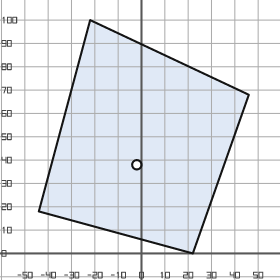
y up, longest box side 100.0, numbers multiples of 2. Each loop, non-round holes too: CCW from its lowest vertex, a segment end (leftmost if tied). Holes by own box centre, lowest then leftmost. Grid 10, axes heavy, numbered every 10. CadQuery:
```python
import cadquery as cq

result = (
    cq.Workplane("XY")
    .moveTo(22.0, 0.0)
    .lineTo(46.0, 68.0)
    .lineTo(-22.0, 100.0)
    .lineTo(-44.0, 18.0)
    .close()
    .moveTo(-2.0, 38.0)
    .circle(2.0)
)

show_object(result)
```